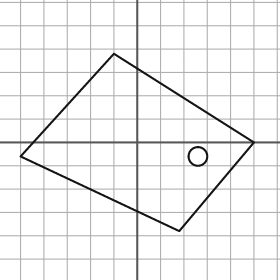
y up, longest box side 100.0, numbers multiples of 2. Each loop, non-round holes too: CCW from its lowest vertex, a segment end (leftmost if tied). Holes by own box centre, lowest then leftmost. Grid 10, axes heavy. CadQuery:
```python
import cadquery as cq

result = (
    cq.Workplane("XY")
    .moveTo(18.0, -38.0)
    .lineTo(50.0, 0.0)
    .lineTo(-10.0, 38.0)
    .lineTo(-50.0, -6.0)
    .close()
    .moveTo(26.0, -6.0)
    .circle(4.0)
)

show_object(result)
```